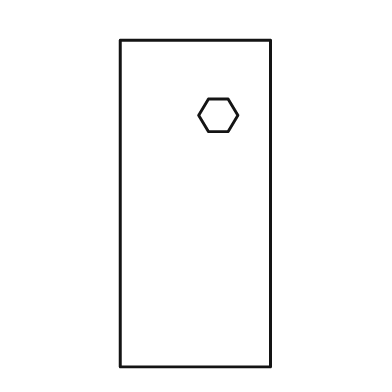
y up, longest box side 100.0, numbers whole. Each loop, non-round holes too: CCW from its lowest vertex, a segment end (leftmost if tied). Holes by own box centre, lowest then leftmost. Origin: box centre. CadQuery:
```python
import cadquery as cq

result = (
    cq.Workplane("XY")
    .moveTo(-23.0, -50.0)
    .lineTo(23.0, -50.0)
    .lineTo(23.0, 50.0)
    .lineTo(-23.0, 50.0)
    .close()
    .moveTo(4.0, 22.0)
    .lineTo(10.0, 22.0)
    .lineTo(13.0, 27.0)
    .lineTo(10.0, 32.0)
    .lineTo(4.0, 32.0)
    .lineTo(1.0, 27.0)
    .close()
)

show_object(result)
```